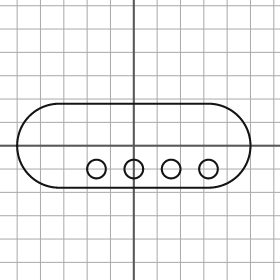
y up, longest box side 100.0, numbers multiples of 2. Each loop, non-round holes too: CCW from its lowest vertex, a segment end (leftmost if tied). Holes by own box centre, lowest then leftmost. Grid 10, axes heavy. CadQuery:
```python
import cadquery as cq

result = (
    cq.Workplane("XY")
    .moveTo(-32.0, -18.0)
    .lineTo(32.0, -18.0)
    .threePointArc((50.0, 0.0), (32.0, 18.0))
    .lineTo(-32.0, 18.0)
    .threePointArc((-50.0, 0.0), (-32.0, -18.0))
    .close()
    .moveTo(-16.0, -10.0)
    .circle(4.0)
    .moveTo(0.0, -10.0)
    .circle(4.0)
    .moveTo(16.0, -10.0)
    .circle(4.0)
    .moveTo(32.0, -10.0)
    .circle(4.0)
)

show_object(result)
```